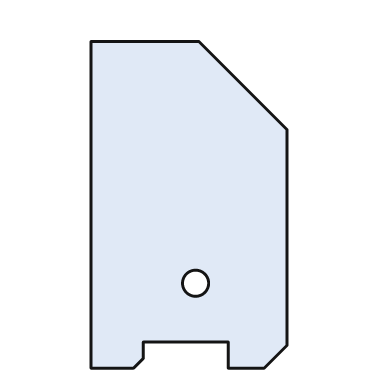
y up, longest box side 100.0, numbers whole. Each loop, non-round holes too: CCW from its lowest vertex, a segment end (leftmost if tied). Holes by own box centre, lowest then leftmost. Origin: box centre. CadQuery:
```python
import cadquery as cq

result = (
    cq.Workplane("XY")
    .moveTo(-30.0, -50.0)
    .lineTo(-17.0, -50.0)
    .lineTo(-14.0, -47.0)
    .lineTo(-14.0, -42.0)
    .lineTo(12.0, -42.0)
    .lineTo(12.0, -50.0)
    .lineTo(23.0, -50.0)
    .lineTo(30.0, -43.0)
    .lineTo(30.0, 23.0)
    .lineTo(3.0, 50.0)
    .lineTo(-30.0, 50.0)
    .close()
    .moveTo(2.0, -24.0)
    .circle(4.0)
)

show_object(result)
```